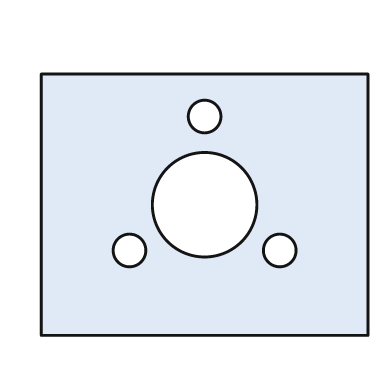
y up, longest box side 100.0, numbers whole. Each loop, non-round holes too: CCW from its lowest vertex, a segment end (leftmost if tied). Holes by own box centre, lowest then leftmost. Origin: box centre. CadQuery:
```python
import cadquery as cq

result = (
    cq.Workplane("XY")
    .moveTo(-50.0, -40.0)
    .lineTo(50.0, -40.0)
    .lineTo(50.0, 40.0)
    .lineTo(-50.0, 40.0)
    .close()
    .moveTo(-23.0, -14.0)
    .circle(5.0)
    .moveTo(23.0, -14.0)
    .circle(5.0)
    .moveTo(0.0, 0.0)
    .circle(16.0)
    .moveTo(0.0, 27.0)
    .circle(5.0)
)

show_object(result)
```